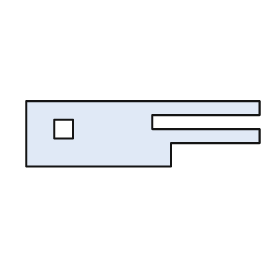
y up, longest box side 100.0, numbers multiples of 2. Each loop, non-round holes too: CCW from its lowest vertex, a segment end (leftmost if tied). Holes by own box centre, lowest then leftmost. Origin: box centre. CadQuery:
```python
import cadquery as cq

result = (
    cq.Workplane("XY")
    .moveTo(-50.0, -14.0)
    .lineTo(12.0, -14.0)
    .lineTo(12.0, -4.0)
    .lineTo(50.0, -4.0)
    .lineTo(50.0, 2.0)
    .lineTo(4.0, 2.0)
    .lineTo(4.0, 8.0)
    .lineTo(50.0, 8.0)
    .lineTo(50.0, 14.0)
    .lineTo(-50.0, 14.0)
    .close()
    .moveTo(-38.0, -2.0)
    .lineTo(-30.0, -2.0)
    .lineTo(-30.0, 6.0)
    .lineTo(-38.0, 6.0)
    .close()
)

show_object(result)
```